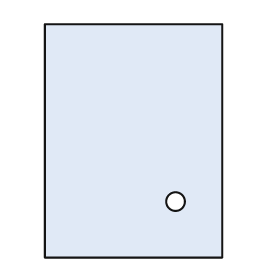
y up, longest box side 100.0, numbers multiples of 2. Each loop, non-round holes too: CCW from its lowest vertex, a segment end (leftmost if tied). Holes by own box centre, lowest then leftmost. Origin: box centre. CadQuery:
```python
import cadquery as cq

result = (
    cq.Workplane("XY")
    .moveTo(-38.0, -50.0)
    .lineTo(38.0, -50.0)
    .lineTo(38.0, 50.0)
    .lineTo(-38.0, 50.0)
    .close()
    .moveTo(18.0, -26.0)
    .circle(4.0)
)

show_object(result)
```